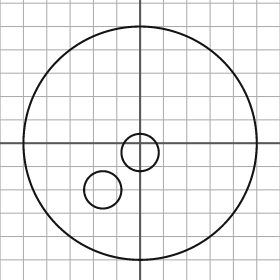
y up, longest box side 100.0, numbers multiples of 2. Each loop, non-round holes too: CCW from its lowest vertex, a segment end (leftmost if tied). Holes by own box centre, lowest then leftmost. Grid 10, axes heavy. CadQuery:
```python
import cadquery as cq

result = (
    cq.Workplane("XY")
    .moveTo(0.0, 0.0)
    .circle(50.0)
    .moveTo(-16.0, -20.0)
    .circle(8.0)
    .moveTo(0.0, -4.0)
    .circle(8.0)
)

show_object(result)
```